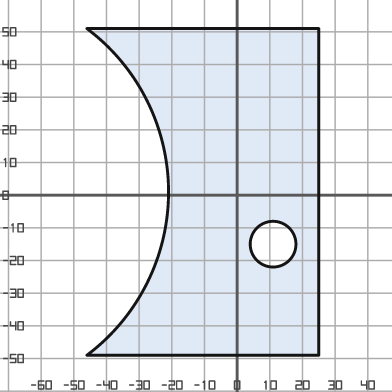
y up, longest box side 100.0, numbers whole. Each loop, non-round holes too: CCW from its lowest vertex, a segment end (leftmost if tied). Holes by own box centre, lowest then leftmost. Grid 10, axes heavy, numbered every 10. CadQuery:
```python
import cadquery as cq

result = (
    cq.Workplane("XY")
    .moveTo(-46.0, -49.0)
    .lineTo(25.0, -49.0)
    .lineTo(25.0, 51.0)
    .lineTo(-46.0, 51.0)
    .threePointArc((-21.0, 1.0), (-46.0, -49.0))
    .close()
    .moveTo(11.0, -15.0)
    .circle(7.0)
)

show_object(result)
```